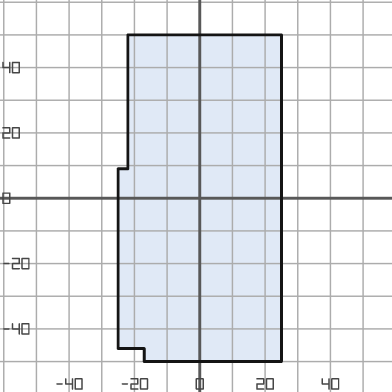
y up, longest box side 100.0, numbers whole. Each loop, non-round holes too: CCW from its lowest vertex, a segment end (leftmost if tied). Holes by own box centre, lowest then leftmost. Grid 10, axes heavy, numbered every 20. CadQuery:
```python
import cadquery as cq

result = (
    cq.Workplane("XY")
    .moveTo(-17.0, -50.0)
    .lineTo(25.0, -50.0)
    .lineTo(25.0, 50.0)
    .lineTo(-22.0, 50.0)
    .lineTo(-22.0, 9.0)
    .lineTo(-25.0, 9.0)
    .lineTo(-25.0, -46.0)
    .lineTo(-17.0, -46.0)
    .close()
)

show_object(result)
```